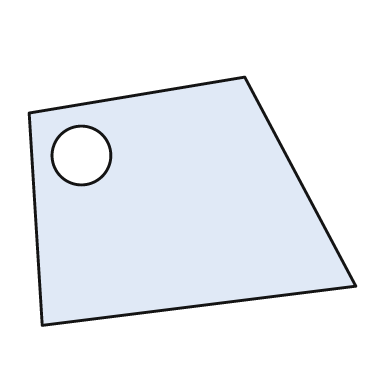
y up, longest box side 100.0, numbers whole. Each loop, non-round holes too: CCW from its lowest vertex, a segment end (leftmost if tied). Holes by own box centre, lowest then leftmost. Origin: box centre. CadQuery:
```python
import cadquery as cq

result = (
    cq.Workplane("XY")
    .moveTo(-46.0, -38.0)
    .lineTo(50.0, -26.0)
    .lineTo(16.0, 38.0)
    .lineTo(-50.0, 27.0)
    .close()
    .moveTo(-34.0, 14.0)
    .circle(9.0)
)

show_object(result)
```